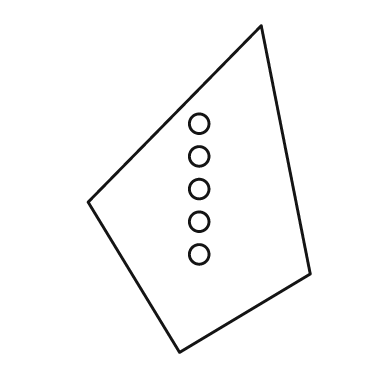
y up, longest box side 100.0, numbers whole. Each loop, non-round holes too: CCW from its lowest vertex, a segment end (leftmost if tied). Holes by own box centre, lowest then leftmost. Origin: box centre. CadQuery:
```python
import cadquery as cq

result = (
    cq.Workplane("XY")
    .moveTo(-6.0, -50.0)
    .lineTo(34.0, -26.0)
    .lineTo(19.0, 50.0)
    .lineTo(-34.0, -4.0)
    .close()
    .moveTo(0.0, -20.0)
    .circle(3.0)
    .moveTo(0.0, -10.0)
    .circle(3.0)
    .moveTo(0.0, 0.0)
    .circle(3.0)
    .moveTo(0.0, 10.0)
    .circle(3.0)
    .moveTo(0.0, 20.0)
    .circle(3.0)
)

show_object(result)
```